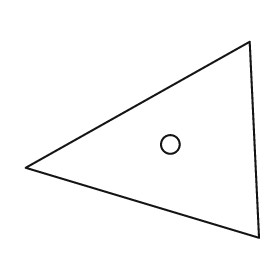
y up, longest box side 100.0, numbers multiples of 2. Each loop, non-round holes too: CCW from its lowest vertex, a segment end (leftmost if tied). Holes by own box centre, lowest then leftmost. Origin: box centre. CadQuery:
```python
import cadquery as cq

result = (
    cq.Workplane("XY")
    .moveTo(50.0, -42.0)
    .lineTo(46.0, 42.0)
    .lineTo(-50.0, -12.0)
    .close()
    .moveTo(12.0, -2.0)
    .circle(4.0)
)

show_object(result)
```